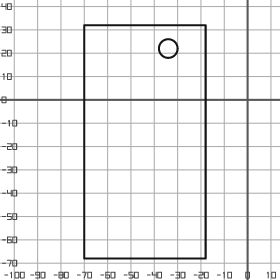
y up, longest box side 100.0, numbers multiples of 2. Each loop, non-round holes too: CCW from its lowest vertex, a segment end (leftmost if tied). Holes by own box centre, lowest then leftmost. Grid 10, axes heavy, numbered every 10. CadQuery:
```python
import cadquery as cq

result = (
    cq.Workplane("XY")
    .moveTo(-70.0, -68.0)
    .lineTo(-18.0, -68.0)
    .lineTo(-18.0, 32.0)
    .lineTo(-70.0, 32.0)
    .close()
    .moveTo(-34.0, 22.0)
    .circle(4.0)
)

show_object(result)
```